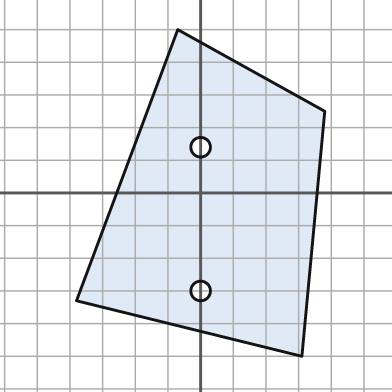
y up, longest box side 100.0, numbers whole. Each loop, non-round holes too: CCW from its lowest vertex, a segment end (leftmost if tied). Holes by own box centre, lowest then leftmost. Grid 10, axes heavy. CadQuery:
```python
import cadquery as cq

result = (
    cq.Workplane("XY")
    .moveTo(31.0, -50.0)
    .lineTo(38.0, 25.0)
    .lineTo(-7.0, 50.0)
    .lineTo(-38.0, -33.0)
    .close()
    .moveTo(0.0, -30.0)
    .circle(3.0)
    .moveTo(0.0, 14.0)
    .circle(3.0)
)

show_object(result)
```